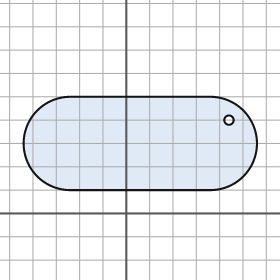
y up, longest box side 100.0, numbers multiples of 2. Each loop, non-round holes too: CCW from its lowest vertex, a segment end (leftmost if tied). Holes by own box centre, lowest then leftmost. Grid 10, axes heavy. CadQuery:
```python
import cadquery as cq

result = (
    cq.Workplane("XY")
    .moveTo(-24.0, 10.0)
    .lineTo(36.0, 10.0)
    .threePointArc((56.0, 30.0), (36.0, 50.0))
    .lineTo(-24.0, 50.0)
    .threePointArc((-44.0, 30.0), (-24.0, 10.0))
    .close()
    .moveTo(44.0, 40.0)
    .circle(2.0)
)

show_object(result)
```